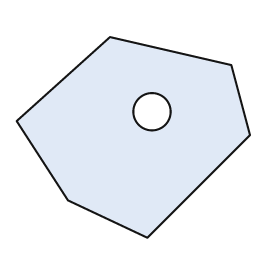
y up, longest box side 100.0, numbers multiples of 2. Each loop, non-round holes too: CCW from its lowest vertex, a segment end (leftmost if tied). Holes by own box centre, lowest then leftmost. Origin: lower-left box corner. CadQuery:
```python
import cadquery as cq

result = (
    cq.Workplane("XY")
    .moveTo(56.0, 0.0)
    .lineTo(100.0, 44.0)
    .lineTo(92.0, 74.0)
    .lineTo(40.0, 86.0)
    .lineTo(0.0, 50.0)
    .lineTo(22.0, 16.0)
    .close()
    .moveTo(58.0, 54.0)
    .circle(8.0)
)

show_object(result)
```